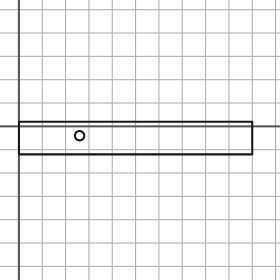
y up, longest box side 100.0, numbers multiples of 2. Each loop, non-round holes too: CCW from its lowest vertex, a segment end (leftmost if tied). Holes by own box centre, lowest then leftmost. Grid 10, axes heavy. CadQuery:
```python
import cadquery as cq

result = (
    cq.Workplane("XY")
    .moveTo(0.0, -12.0)
    .lineTo(100.0, -12.0)
    .lineTo(100.0, 2.0)
    .lineTo(0.0, 2.0)
    .close()
    .moveTo(26.0, -4.0)
    .circle(2.0)
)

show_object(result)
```